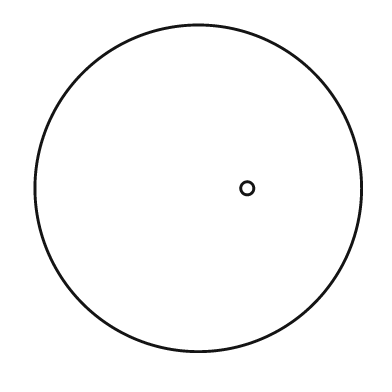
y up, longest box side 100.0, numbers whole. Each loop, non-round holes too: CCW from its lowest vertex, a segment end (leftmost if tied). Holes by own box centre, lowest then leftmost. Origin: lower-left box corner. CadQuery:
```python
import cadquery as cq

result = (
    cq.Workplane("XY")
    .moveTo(50.0, 50.0)
    .circle(50.0)
    .moveTo(65.0, 50.0)
    .circle(2.0)
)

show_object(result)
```